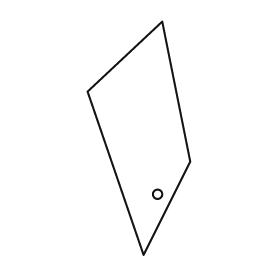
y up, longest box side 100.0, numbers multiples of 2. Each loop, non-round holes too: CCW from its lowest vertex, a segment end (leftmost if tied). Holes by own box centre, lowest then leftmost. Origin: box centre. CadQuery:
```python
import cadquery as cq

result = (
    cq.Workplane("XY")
    .moveTo(2.0, -50.0)
    .lineTo(22.0, -10.0)
    .lineTo(10.0, 50.0)
    .lineTo(-22.0, 20.0)
    .close()
    .moveTo(8.0, -24.0)
    .circle(2.0)
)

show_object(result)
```